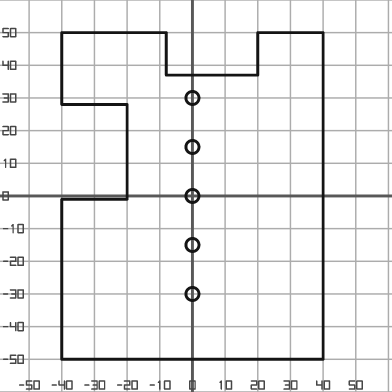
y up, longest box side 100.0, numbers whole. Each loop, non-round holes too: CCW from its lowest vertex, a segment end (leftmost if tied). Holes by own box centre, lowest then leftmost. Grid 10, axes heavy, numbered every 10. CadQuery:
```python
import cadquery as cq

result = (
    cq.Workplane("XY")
    .moveTo(-40.0, -50.0)
    .lineTo(40.0, -50.0)
    .lineTo(40.0, 50.0)
    .lineTo(20.0, 50.0)
    .lineTo(20.0, 37.0)
    .lineTo(-8.0, 37.0)
    .lineTo(-8.0, 50.0)
    .lineTo(-40.0, 50.0)
    .lineTo(-40.0, 28.0)
    .lineTo(-20.0, 28.0)
    .lineTo(-20.0, -1.0)
    .lineTo(-40.0, -1.0)
    .close()
    .moveTo(0.0, -30.0)
    .circle(2.0)
    .moveTo(0.0, -15.0)
    .circle(2.0)
    .moveTo(0.0, 0.0)
    .circle(2.0)
    .moveTo(0.0, 15.0)
    .circle(2.0)
    .moveTo(0.0, 30.0)
    .circle(2.0)
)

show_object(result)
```